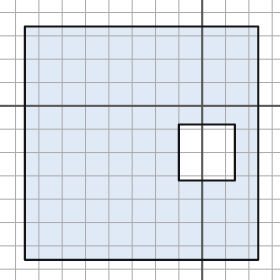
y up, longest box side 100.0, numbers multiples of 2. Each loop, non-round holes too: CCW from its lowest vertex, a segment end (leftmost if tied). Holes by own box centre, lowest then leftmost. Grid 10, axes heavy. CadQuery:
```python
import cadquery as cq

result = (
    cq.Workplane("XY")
    .moveTo(-76.0, -66.0)
    .lineTo(24.0, -66.0)
    .lineTo(24.0, 34.0)
    .lineTo(-76.0, 34.0)
    .close()
    .moveTo(-10.0, -32.0)
    .lineTo(14.0, -32.0)
    .lineTo(14.0, -8.0)
    .lineTo(-10.0, -8.0)
    .close()
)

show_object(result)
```